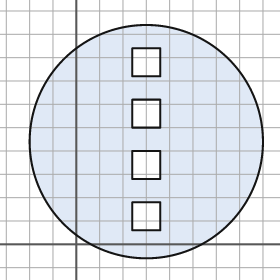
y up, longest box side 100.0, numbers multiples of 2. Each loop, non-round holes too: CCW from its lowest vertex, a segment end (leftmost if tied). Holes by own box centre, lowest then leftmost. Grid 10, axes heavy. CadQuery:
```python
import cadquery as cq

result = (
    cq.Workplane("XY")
    .moveTo(30.0, 44.0)
    .circle(50.0)
    .moveTo(24.0, 6.0)
    .lineTo(36.0, 6.0)
    .lineTo(36.0, 18.0)
    .lineTo(24.0, 18.0)
    .close()
    .moveTo(24.0, 28.0)
    .lineTo(36.0, 28.0)
    .lineTo(36.0, 40.0)
    .lineTo(24.0, 40.0)
    .close()
    .moveTo(24.0, 50.0)
    .lineTo(36.0, 50.0)
    .lineTo(36.0, 62.0)
    .lineTo(24.0, 62.0)
    .close()
    .moveTo(24.0, 72.0)
    .lineTo(36.0, 72.0)
    .lineTo(36.0, 84.0)
    .lineTo(24.0, 84.0)
    .close()
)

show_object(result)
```